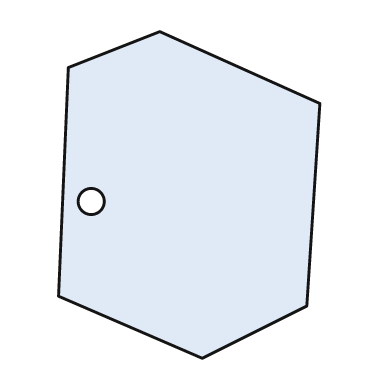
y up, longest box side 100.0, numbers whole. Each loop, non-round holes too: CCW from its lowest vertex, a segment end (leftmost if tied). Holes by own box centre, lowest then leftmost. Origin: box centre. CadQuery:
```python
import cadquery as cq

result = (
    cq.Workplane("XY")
    .moveTo(4.0, -50.0)
    .lineTo(36.0, -34.0)
    .lineTo(40.0, 28.0)
    .lineTo(-9.0, 50.0)
    .lineTo(-37.0, 39.0)
    .lineTo(-40.0, -31.0)
    .close()
    .moveTo(-30.0, -2.0)
    .circle(4.0)
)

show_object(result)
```